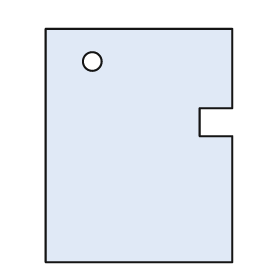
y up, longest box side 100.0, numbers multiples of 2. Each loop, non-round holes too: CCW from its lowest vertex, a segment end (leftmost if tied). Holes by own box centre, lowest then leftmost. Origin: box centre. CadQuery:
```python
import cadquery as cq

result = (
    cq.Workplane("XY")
    .moveTo(-40.0, -50.0)
    .lineTo(40.0, -50.0)
    .lineTo(40.0, 4.0)
    .lineTo(26.0, 4.0)
    .lineTo(26.0, 16.0)
    .lineTo(40.0, 16.0)
    .lineTo(40.0, 50.0)
    .lineTo(-40.0, 50.0)
    .close()
    .moveTo(-20.0, 36.0)
    .circle(4.0)
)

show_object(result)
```